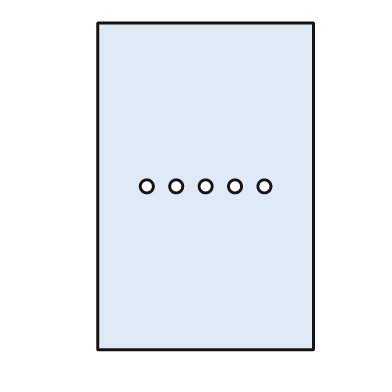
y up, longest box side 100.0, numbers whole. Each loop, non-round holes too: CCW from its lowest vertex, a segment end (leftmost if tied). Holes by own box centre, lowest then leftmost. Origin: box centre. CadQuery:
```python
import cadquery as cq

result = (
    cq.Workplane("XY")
    .moveTo(-33.0, -50.0)
    .lineTo(33.0, -50.0)
    .lineTo(33.0, 50.0)
    .lineTo(-33.0, 50.0)
    .close()
    .moveTo(-18.0, 0.0)
    .circle(2.0)
    .moveTo(-9.0, 0.0)
    .circle(2.0)
    .moveTo(0.0, 0.0)
    .circle(2.0)
    .moveTo(9.0, 0.0)
    .circle(2.0)
    .moveTo(18.0, 0.0)
    .circle(2.0)
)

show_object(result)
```